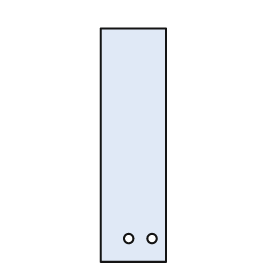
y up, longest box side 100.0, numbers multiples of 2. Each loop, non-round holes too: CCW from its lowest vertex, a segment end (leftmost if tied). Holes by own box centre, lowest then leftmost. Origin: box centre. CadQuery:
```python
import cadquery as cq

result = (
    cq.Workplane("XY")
    .moveTo(-14.0, -50.0)
    .lineTo(14.0, -50.0)
    .lineTo(14.0, 50.0)
    .lineTo(-14.0, 50.0)
    .close()
    .moveTo(-2.0, -40.0)
    .circle(2.0)
    .moveTo(8.0, -40.0)
    .circle(2.0)
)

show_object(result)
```